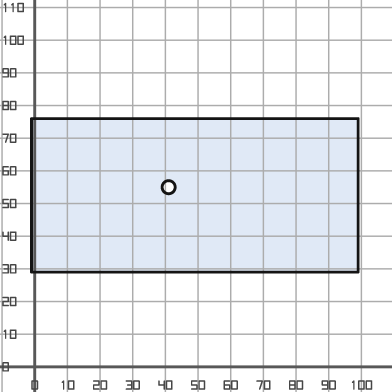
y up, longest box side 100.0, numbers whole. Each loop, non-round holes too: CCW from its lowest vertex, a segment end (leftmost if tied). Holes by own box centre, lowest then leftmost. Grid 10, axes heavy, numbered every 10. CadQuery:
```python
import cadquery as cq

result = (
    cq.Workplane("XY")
    .moveTo(-1.0, 29.0)
    .lineTo(99.0, 29.0)
    .lineTo(99.0, 76.0)
    .lineTo(-1.0, 76.0)
    .close()
    .moveTo(41.0, 55.0)
    .circle(2.0)
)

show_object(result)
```